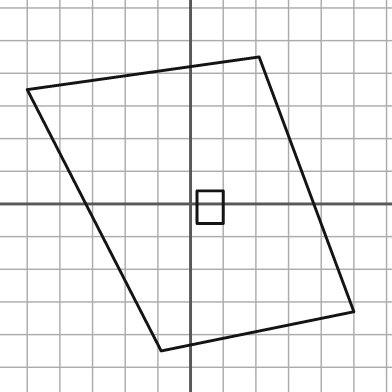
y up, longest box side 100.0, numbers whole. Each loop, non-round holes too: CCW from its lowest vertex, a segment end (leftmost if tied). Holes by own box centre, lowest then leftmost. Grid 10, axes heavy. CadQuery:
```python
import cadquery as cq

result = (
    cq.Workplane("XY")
    .moveTo(-9.0, -45.0)
    .lineTo(50.0, -33.0)
    .lineTo(21.0, 45.0)
    .lineTo(-50.0, 35.0)
    .close()
    .moveTo(2.0, -6.0)
    .lineTo(10.0, -6.0)
    .lineTo(10.0, 4.0)
    .lineTo(2.0, 4.0)
    .close()
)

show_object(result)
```